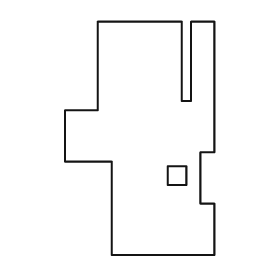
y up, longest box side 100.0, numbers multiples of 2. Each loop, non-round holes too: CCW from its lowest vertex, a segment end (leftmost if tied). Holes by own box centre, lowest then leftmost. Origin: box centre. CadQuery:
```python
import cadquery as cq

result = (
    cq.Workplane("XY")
    .moveTo(-12.0, -50.0)
    .lineTo(32.0, -50.0)
    .lineTo(32.0, -28.0)
    .lineTo(26.0, -28.0)
    .lineTo(26.0, -6.0)
    .lineTo(32.0, -6.0)
    .lineTo(32.0, 50.0)
    .lineTo(22.0, 50.0)
    .lineTo(22.0, 16.0)
    .lineTo(18.0, 16.0)
    .lineTo(18.0, 50.0)
    .lineTo(-18.0, 50.0)
    .lineTo(-18.0, 12.0)
    .lineTo(-32.0, 12.0)
    .lineTo(-32.0, -10.0)
    .lineTo(-12.0, -10.0)
    .close()
    .moveTo(12.0, -20.0)
    .lineTo(20.0, -20.0)
    .lineTo(20.0, -12.0)
    .lineTo(12.0, -12.0)
    .close()
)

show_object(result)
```